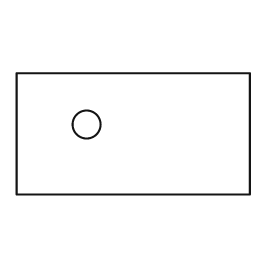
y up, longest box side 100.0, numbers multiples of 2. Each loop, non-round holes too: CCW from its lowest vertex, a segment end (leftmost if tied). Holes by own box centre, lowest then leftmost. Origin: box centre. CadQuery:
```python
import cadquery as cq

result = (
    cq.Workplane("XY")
    .moveTo(-50.0, -26.0)
    .lineTo(50.0, -26.0)
    .lineTo(50.0, 26.0)
    .lineTo(-50.0, 26.0)
    .close()
    .moveTo(-20.0, 4.0)
    .circle(6.0)
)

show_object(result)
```